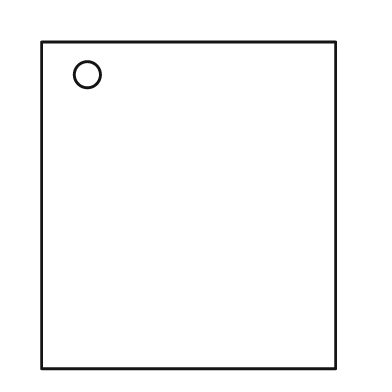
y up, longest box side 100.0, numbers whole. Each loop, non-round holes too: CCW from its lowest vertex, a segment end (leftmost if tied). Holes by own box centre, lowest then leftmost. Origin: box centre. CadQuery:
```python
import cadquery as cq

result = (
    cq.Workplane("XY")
    .moveTo(-45.0, -50.0)
    .lineTo(45.0, -50.0)
    .lineTo(45.0, 50.0)
    .lineTo(-45.0, 50.0)
    .close()
    .moveTo(-31.0, 40.0)
    .circle(4.0)
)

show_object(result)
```